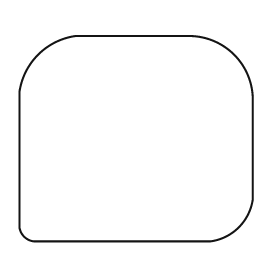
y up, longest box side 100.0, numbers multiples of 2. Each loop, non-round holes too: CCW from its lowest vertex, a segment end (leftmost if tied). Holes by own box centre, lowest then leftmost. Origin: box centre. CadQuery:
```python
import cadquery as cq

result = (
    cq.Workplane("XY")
    .moveTo(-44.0, -44.0)
    .lineTo(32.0, -44.0)
    .threePointArc((44.0, -38.0), (50.0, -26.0))
    .lineTo(50.0, 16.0)
    .threePointArc((42.0, 36.0), (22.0, 44.0))
    .lineTo(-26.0, 44.0)
    .threePointArc((-42.0, 36.0), (-50.0, 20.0))
    .lineTo(-50.0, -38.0)
    .threePointArc((-48.0, -42.0), (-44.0, -44.0))
    .close()
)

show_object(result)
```